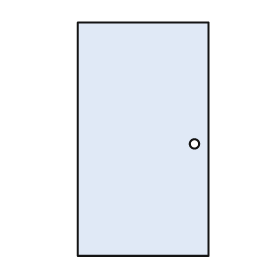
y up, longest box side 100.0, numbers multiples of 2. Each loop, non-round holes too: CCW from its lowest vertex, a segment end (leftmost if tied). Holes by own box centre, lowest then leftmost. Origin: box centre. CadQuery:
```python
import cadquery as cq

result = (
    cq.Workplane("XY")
    .moveTo(-28.0, -50.0)
    .lineTo(28.0, -50.0)
    .lineTo(28.0, 50.0)
    .lineTo(-28.0, 50.0)
    .close()
    .moveTo(22.0, -2.0)
    .circle(2.0)
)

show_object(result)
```